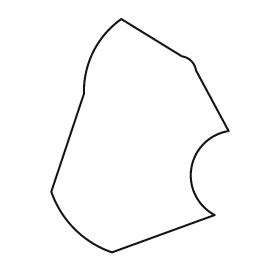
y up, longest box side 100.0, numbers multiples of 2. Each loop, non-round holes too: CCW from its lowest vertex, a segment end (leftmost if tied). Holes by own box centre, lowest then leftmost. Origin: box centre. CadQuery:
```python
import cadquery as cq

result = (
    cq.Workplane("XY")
    .moveTo(-12.0, -50.0)
    .lineTo(32.0, -34.0)
    .threePointArc((22.0, -14.0), (38.0, 2.0))
    .lineTo(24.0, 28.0)
    .threePointArc((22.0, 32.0), (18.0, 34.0))
    .lineTo(-8.0, 50.0)
    .threePointArc((-20.0, 36.0), (-24.0, 18.0))
    .lineTo(-38.0, -24.0)
    .threePointArc((-28.0, -40.0), (-12.0, -50.0))
    .close()
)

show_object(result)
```